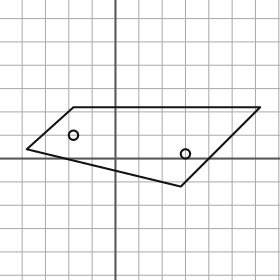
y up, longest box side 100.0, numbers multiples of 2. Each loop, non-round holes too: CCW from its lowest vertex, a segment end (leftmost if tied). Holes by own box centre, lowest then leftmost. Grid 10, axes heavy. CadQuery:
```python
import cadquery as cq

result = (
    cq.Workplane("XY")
    .moveTo(28.0, -12.0)
    .lineTo(62.0, 22.0)
    .lineTo(-18.0, 22.0)
    .lineTo(-38.0, 4.0)
    .close()
    .moveTo(30.0, 2.0)
    .circle(2.0)
    .moveTo(-18.0, 10.0)
    .circle(2.0)
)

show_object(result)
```